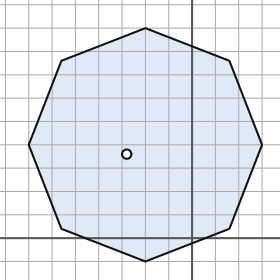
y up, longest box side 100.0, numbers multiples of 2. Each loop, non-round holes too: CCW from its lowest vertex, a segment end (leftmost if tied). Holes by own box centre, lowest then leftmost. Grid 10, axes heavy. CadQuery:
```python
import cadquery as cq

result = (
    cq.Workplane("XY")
    .moveTo(-20.0, -10.0)
    .lineTo(16.0, 4.0)
    .lineTo(30.0, 40.0)
    .lineTo(16.0, 76.0)
    .lineTo(-20.0, 90.0)
    .lineTo(-56.0, 76.0)
    .lineTo(-70.0, 40.0)
    .lineTo(-56.0, 4.0)
    .close()
    .moveTo(-28.0, 36.0)
    .circle(2.0)
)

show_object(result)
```